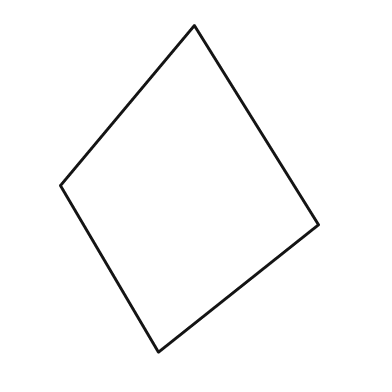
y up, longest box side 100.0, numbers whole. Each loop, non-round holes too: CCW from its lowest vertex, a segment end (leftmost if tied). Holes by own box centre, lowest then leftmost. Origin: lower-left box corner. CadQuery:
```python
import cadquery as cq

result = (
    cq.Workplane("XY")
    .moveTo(30.0, 0.0)
    .lineTo(79.0, 39.0)
    .lineTo(41.0, 100.0)
    .lineTo(0.0, 51.0)
    .close()
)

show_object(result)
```